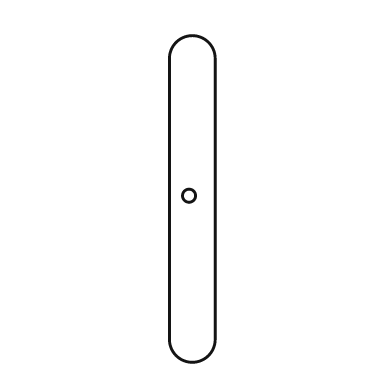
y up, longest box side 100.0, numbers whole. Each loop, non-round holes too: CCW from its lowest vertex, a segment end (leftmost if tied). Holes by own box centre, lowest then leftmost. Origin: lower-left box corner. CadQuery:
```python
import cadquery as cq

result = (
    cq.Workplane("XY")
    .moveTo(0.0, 7.0)
    .threePointArc((7.0, 0.0), (14.0, 7.0))
    .lineTo(14.0, 93.0)
    .threePointArc((7.0, 100.0), (0.0, 93.0))
    .close()
    .moveTo(6.0, 51.0)
    .circle(2.0)
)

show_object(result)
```